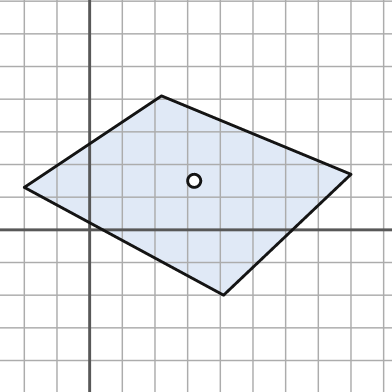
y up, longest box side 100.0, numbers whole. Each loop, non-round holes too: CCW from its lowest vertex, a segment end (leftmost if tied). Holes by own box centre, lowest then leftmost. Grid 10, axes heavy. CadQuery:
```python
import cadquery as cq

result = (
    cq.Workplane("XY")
    .moveTo(41.0, -20.0)
    .lineTo(80.0, 17.0)
    .lineTo(22.0, 41.0)
    .lineTo(-20.0, 13.0)
    .close()
    .moveTo(32.0, 15.0)
    .circle(2.0)
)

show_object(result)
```